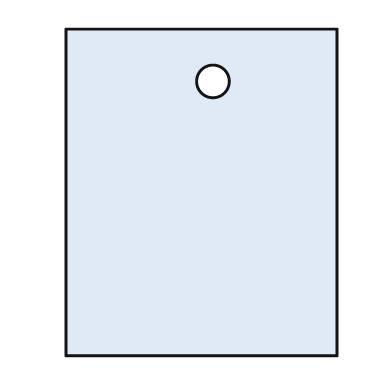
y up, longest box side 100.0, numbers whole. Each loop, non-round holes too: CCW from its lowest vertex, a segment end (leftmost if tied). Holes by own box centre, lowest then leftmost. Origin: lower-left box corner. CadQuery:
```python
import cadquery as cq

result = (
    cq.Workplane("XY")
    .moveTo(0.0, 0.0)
    .lineTo(83.0, 0.0)
    .lineTo(83.0, 100.0)
    .lineTo(0.0, 100.0)
    .close()
    .moveTo(45.0, 84.0)
    .circle(5.0)
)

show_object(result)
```